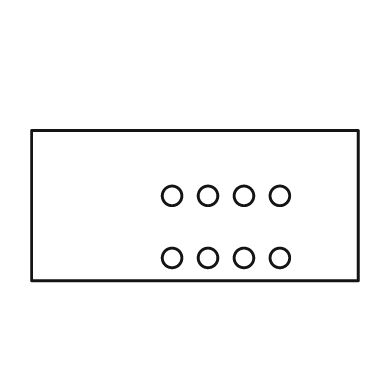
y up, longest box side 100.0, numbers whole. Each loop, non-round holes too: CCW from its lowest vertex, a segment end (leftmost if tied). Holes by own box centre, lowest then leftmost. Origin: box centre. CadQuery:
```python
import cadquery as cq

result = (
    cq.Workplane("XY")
    .moveTo(-50.0, -23.0)
    .lineTo(50.0, -23.0)
    .lineTo(50.0, 23.0)
    .lineTo(-50.0, 23.0)
    .close()
    .moveTo(-7.0, -16.0)
    .circle(3.0)
    .moveTo(4.0, -16.0)
    .circle(3.0)
    .moveTo(15.0, -16.0)
    .circle(3.0)
    .moveTo(26.0, -16.0)
    .circle(3.0)
    .moveTo(-7.0, 3.0)
    .circle(3.0)
    .moveTo(4.0, 3.0)
    .circle(3.0)
    .moveTo(15.0, 3.0)
    .circle(3.0)
    .moveTo(26.0, 3.0)
    .circle(3.0)
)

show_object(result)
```